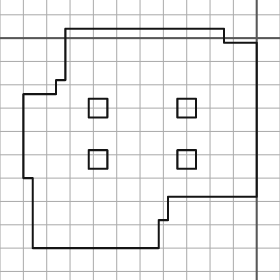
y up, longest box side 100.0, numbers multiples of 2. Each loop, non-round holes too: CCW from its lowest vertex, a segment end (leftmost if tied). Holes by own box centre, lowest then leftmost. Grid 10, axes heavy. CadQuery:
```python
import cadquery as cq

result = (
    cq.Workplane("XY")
    .moveTo(-96.0, -90.0)
    .lineTo(-42.0, -90.0)
    .lineTo(-42.0, -78.0)
    .lineTo(-38.0, -78.0)
    .lineTo(-38.0, -68.0)
    .lineTo(0.0, -68.0)
    .lineTo(0.0, -2.0)
    .lineTo(-14.0, -2.0)
    .lineTo(-14.0, 4.0)
    .lineTo(-82.0, 4.0)
    .lineTo(-82.0, -18.0)
    .lineTo(-86.0, -18.0)
    .lineTo(-86.0, -24.0)
    .lineTo(-100.0, -24.0)
    .lineTo(-100.0, -60.0)
    .lineTo(-96.0, -60.0)
    .close()
    .moveTo(-72.0, -56.0)
    .lineTo(-64.0, -56.0)
    .lineTo(-64.0, -48.0)
    .lineTo(-72.0, -48.0)
    .close()
    .moveTo(-34.0, -56.0)
    .lineTo(-26.0, -56.0)
    .lineTo(-26.0, -48.0)
    .lineTo(-34.0, -48.0)
    .close()
    .moveTo(-72.0, -34.0)
    .lineTo(-64.0, -34.0)
    .lineTo(-64.0, -26.0)
    .lineTo(-72.0, -26.0)
    .close()
    .moveTo(-34.0, -34.0)
    .lineTo(-26.0, -34.0)
    .lineTo(-26.0, -26.0)
    .lineTo(-34.0, -26.0)
    .close()
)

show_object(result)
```